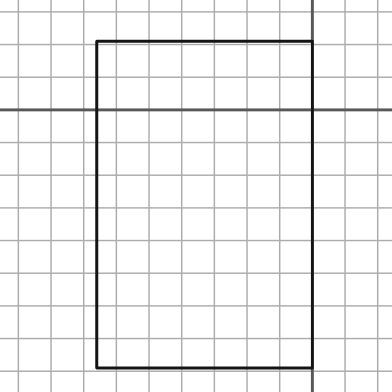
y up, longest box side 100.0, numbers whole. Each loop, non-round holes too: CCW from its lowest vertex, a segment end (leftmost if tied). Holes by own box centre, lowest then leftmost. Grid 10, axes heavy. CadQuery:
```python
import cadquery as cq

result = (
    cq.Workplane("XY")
    .moveTo(-66.0, -79.0)
    .lineTo(0.0, -79.0)
    .lineTo(0.0, 21.0)
    .lineTo(-66.0, 21.0)
    .close()
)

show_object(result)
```